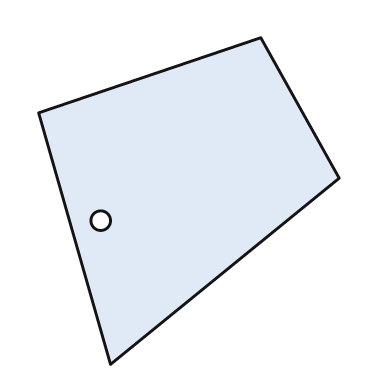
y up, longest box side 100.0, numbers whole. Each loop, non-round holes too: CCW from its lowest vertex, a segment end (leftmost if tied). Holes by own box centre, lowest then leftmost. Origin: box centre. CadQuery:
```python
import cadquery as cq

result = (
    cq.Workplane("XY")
    .moveTo(-24.0, -50.0)
    .lineTo(46.0, 7.0)
    .lineTo(22.0, 50.0)
    .lineTo(-46.0, 27.0)
    .close()
    .moveTo(-27.0, -6.0)
    .circle(3.0)
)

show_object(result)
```